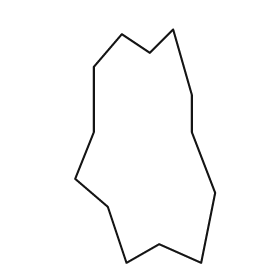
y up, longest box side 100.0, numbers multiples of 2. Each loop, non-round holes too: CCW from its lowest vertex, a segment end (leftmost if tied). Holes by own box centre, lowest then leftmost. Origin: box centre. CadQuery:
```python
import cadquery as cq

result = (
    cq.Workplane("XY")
    .moveTo(-8.0, -50.0)
    .lineTo(6.0, -42.0)
    .lineTo(24.0, -50.0)
    .lineTo(30.0, -20.0)
    .lineTo(20.0, 6.0)
    .lineTo(20.0, 22.0)
    .lineTo(12.0, 50.0)
    .lineTo(2.0, 40.0)
    .lineTo(-10.0, 48.0)
    .lineTo(-22.0, 34.0)
    .lineTo(-22.0, 6.0)
    .lineTo(-30.0, -14.0)
    .lineTo(-16.0, -26.0)
    .close()
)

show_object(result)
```